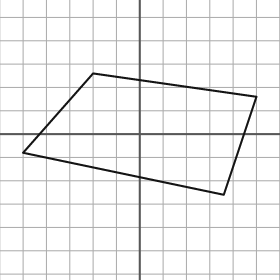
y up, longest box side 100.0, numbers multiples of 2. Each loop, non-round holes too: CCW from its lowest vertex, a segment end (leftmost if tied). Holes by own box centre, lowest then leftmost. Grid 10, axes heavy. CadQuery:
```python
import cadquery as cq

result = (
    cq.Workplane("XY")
    .moveTo(36.0, -26.0)
    .lineTo(50.0, 16.0)
    .lineTo(-20.0, 26.0)
    .lineTo(-50.0, -8.0)
    .close()
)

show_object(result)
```